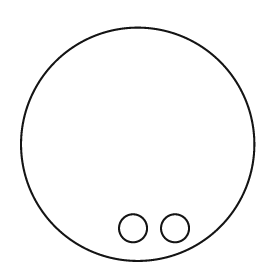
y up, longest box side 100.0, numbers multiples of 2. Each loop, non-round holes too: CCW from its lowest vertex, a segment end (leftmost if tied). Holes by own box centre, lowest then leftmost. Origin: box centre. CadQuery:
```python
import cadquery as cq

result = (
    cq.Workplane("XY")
    .moveTo(0.0, 0.0)
    .circle(50.0)
    .moveTo(-2.0, -36.0)
    .circle(6.0)
    .moveTo(16.0, -36.0)
    .circle(6.0)
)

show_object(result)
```